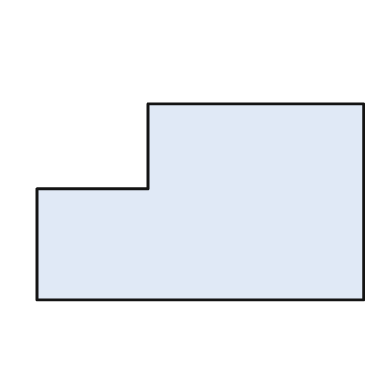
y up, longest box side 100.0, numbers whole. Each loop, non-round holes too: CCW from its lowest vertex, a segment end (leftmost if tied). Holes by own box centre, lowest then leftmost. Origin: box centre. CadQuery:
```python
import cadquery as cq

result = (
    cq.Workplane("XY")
    .moveTo(-50.0, -30.0)
    .lineTo(50.0, -30.0)
    .lineTo(50.0, 30.0)
    .lineTo(-16.0, 30.0)
    .lineTo(-16.0, 4.0)
    .lineTo(-50.0, 4.0)
    .close()
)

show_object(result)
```